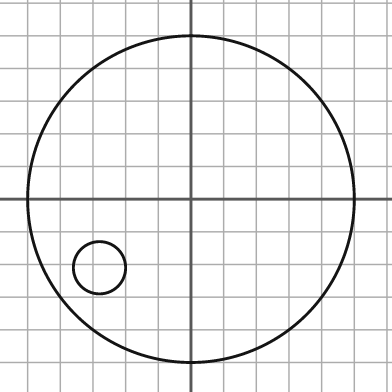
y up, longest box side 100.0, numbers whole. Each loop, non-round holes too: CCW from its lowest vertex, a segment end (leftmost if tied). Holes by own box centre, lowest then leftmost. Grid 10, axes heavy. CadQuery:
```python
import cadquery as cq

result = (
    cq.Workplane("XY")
    .moveTo(0.0, 0.0)
    .circle(50.0)
    .moveTo(-28.0, -21.0)
    .circle(8.0)
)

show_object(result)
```